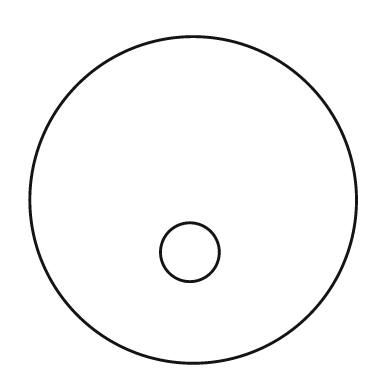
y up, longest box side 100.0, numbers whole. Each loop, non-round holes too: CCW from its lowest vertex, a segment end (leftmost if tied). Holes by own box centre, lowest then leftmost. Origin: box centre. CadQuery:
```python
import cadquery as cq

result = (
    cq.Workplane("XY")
    .moveTo(0.0, 0.0)
    .circle(50.0)
    .moveTo(-1.0, -16.0)
    .circle(9.0)
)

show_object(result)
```